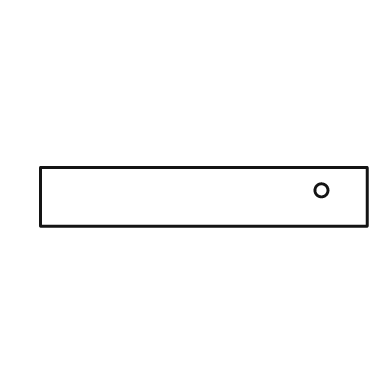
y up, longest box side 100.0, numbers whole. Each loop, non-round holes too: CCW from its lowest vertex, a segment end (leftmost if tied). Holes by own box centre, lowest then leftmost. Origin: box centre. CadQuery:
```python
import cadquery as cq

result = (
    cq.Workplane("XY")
    .moveTo(-50.0, -9.0)
    .lineTo(50.0, -9.0)
    .lineTo(50.0, 9.0)
    .lineTo(-50.0, 9.0)
    .close()
    .moveTo(36.0, 2.0)
    .circle(2.0)
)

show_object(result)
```